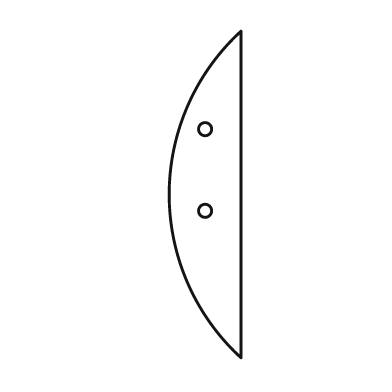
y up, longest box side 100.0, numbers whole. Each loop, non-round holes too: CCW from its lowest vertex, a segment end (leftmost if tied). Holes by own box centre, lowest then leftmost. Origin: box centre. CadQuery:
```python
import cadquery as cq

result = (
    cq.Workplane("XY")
    .moveTo(11.0, -50.0)
    .lineTo(11.0, 50.0)
    .threePointArc((-11.0, 0.0), (11.0, -50.0))
    .close()
    .moveTo(0.0, -5.0)
    .circle(2.0)
    .moveTo(0.0, 20.0)
    .circle(2.0)
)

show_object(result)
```